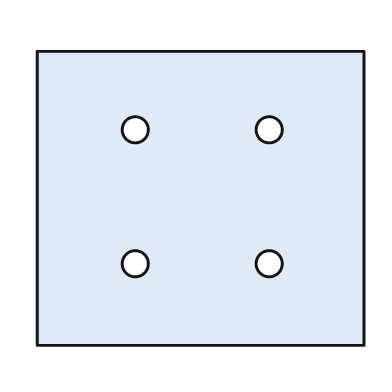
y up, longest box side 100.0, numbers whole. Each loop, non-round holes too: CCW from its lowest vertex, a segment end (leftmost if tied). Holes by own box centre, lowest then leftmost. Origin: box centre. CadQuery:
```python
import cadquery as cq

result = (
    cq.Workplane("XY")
    .moveTo(-50.0, -45.0)
    .lineTo(50.0, -45.0)
    .lineTo(50.0, 45.0)
    .lineTo(-50.0, 45.0)
    .close()
    .moveTo(-20.0, -20.0)
    .circle(4.0)
    .moveTo(21.0, -20.0)
    .circle(4.0)
    .moveTo(-20.0, 21.0)
    .circle(4.0)
    .moveTo(21.0, 21.0)
    .circle(4.0)
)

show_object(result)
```